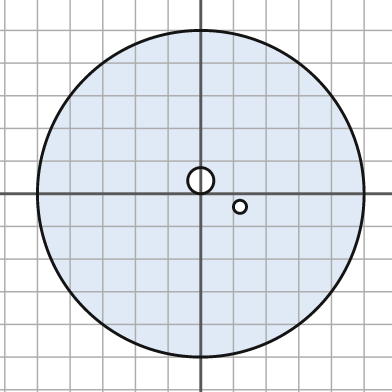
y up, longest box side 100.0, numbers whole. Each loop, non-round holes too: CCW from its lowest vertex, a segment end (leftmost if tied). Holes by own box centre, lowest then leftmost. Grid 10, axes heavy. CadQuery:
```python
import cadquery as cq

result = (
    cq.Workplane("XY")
    .moveTo(0.0, 0.0)
    .circle(50.0)
    .moveTo(12.0, -4.0)
    .circle(2.0)
    .moveTo(0.0, 4.0)
    .circle(4.0)
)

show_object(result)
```